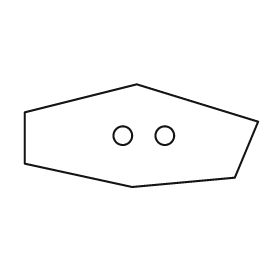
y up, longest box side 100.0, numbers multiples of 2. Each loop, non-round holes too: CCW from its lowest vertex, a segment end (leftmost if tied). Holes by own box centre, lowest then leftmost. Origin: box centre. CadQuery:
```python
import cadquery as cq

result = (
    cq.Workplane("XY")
    .moveTo(-4.0, -22.0)
    .lineTo(40.0, -18.0)
    .lineTo(50.0, 6.0)
    .lineTo(-2.0, 22.0)
    .lineTo(-50.0, 10.0)
    .lineTo(-50.0, -12.0)
    .close()
    .moveTo(-8.0, 0.0)
    .circle(4.0)
    .moveTo(10.0, 0.0)
    .circle(4.0)
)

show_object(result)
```